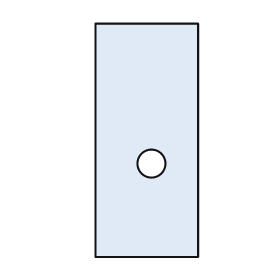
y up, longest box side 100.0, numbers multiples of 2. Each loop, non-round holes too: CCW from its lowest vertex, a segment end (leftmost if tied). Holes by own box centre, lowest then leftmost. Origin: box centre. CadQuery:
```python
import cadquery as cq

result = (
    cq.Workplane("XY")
    .moveTo(-22.0, -50.0)
    .lineTo(22.0, -50.0)
    .lineTo(22.0, 50.0)
    .lineTo(-22.0, 50.0)
    .close()
    .moveTo(2.0, -10.0)
    .circle(6.0)
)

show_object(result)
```